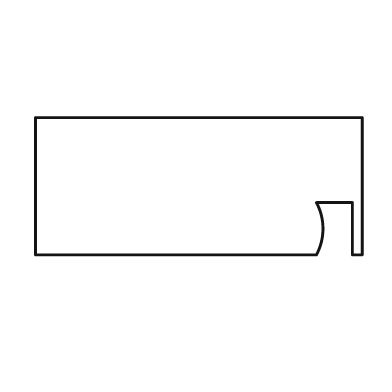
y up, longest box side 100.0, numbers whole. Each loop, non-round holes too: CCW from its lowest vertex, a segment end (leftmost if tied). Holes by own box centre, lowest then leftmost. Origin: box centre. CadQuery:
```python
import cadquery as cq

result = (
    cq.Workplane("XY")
    .moveTo(-50.0, -21.0)
    .lineTo(36.0, -21.0)
    .threePointArc((38.0, -13.0), (36.0, -5.0))
    .lineTo(47.0, -5.0)
    .lineTo(47.0, -21.0)
    .lineTo(50.0, -21.0)
    .lineTo(50.0, 21.0)
    .lineTo(-50.0, 21.0)
    .close()
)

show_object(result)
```